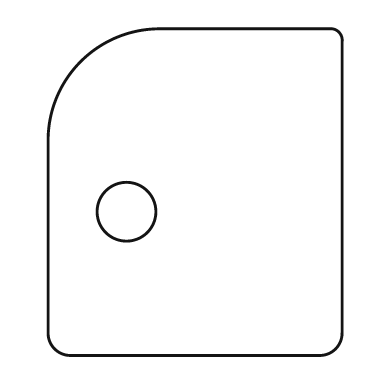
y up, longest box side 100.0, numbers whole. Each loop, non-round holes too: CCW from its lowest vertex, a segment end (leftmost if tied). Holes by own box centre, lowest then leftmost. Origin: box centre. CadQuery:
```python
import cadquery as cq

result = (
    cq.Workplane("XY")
    .moveTo(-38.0, -50.0)
    .lineTo(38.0, -50.0)
    .threePointArc((43.0, -48.0), (45.0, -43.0))
    .lineTo(45.0, 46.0)
    .threePointArc((44.0, 49.0), (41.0, 50.0))
    .lineTo(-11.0, 50.0)
    .threePointArc((-35.0, 40.0), (-45.0, 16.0))
    .lineTo(-45.0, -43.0)
    .threePointArc((-43.0, -48.0), (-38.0, -50.0))
    .close()
    .moveTo(-21.0, -6.0)
    .circle(9.0)
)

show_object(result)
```